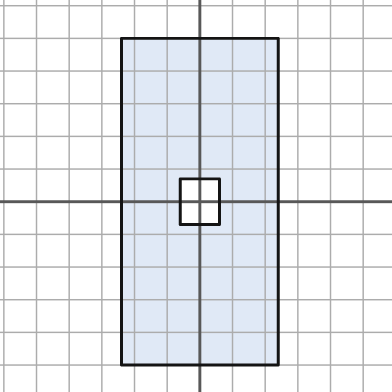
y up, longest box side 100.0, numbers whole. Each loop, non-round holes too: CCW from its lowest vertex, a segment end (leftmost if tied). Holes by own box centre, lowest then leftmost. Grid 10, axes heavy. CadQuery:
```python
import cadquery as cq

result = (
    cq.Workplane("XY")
    .moveTo(-24.0, -50.0)
    .lineTo(24.0, -50.0)
    .lineTo(24.0, 50.0)
    .lineTo(-24.0, 50.0)
    .close()
    .moveTo(-6.0, -7.0)
    .lineTo(6.0, -7.0)
    .lineTo(6.0, 7.0)
    .lineTo(-6.0, 7.0)
    .close()
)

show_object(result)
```